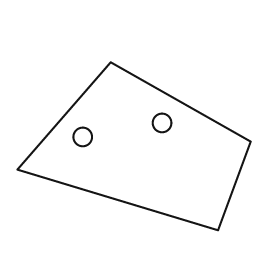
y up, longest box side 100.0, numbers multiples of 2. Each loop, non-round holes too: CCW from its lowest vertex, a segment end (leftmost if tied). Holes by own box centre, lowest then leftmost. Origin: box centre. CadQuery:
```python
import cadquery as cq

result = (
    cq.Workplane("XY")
    .moveTo(36.0, -36.0)
    .lineTo(50.0, 2.0)
    .lineTo(-10.0, 36.0)
    .lineTo(-50.0, -10.0)
    .close()
    .moveTo(-22.0, 4.0)
    .circle(4.0)
    .moveTo(12.0, 10.0)
    .circle(4.0)
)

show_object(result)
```